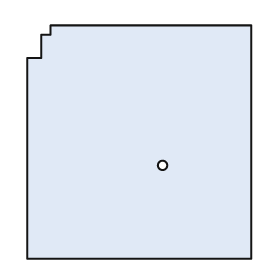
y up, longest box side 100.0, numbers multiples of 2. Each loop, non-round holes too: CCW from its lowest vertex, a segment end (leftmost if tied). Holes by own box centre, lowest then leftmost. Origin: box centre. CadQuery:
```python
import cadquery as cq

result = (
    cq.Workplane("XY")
    .moveTo(-48.0, -50.0)
    .lineTo(48.0, -50.0)
    .lineTo(48.0, 50.0)
    .lineTo(-38.0, 50.0)
    .lineTo(-38.0, 46.0)
    .lineTo(-42.0, 46.0)
    .lineTo(-42.0, 36.0)
    .lineTo(-48.0, 36.0)
    .close()
    .moveTo(10.0, -10.0)
    .circle(2.0)
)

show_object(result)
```